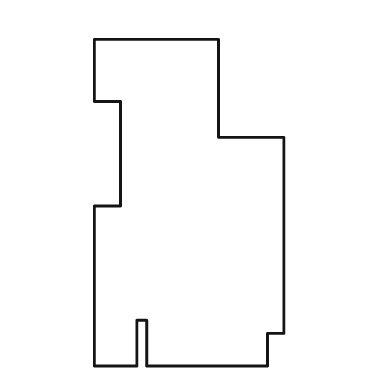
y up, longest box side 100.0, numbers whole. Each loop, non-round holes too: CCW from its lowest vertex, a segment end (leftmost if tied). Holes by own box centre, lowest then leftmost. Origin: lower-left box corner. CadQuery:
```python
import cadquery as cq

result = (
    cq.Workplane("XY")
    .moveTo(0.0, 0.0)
    .lineTo(13.0, 0.0)
    .lineTo(13.0, 14.0)
    .lineTo(16.0, 14.0)
    .lineTo(16.0, 0.0)
    .lineTo(53.0, 0.0)
    .lineTo(53.0, 10.0)
    .lineTo(58.0, 10.0)
    .lineTo(58.0, 70.0)
    .lineTo(38.0, 70.0)
    .lineTo(38.0, 100.0)
    .lineTo(0.0, 100.0)
    .lineTo(0.0, 81.0)
    .lineTo(8.0, 81.0)
    .lineTo(8.0, 49.0)
    .lineTo(0.0, 49.0)
    .close()
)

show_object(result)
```